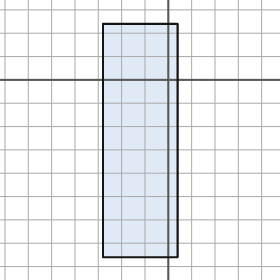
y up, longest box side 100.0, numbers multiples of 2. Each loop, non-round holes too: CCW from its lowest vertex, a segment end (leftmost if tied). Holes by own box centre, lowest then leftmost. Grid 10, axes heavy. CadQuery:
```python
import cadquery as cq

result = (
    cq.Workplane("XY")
    .moveTo(-28.0, -76.0)
    .lineTo(4.0, -76.0)
    .lineTo(4.0, 24.0)
    .lineTo(-28.0, 24.0)
    .close()
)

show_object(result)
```